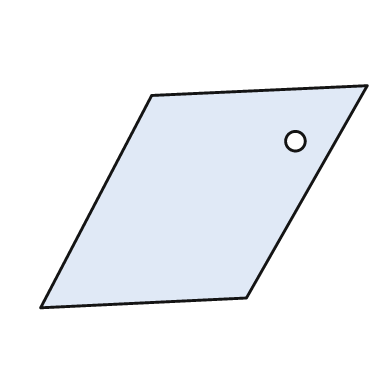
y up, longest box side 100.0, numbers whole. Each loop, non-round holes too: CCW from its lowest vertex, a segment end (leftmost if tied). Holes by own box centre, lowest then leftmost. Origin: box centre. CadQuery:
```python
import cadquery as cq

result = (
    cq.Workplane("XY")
    .moveTo(-50.0, -34.0)
    .lineTo(13.0, -31.0)
    .lineTo(50.0, 34.0)
    .lineTo(-16.0, 31.0)
    .close()
    .moveTo(28.0, 17.0)
    .circle(3.0)
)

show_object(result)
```